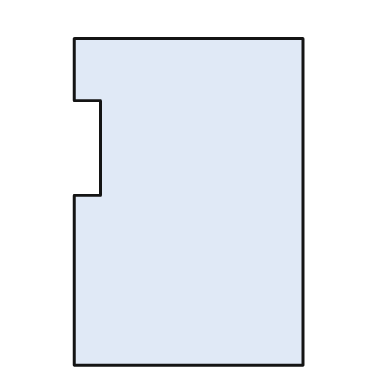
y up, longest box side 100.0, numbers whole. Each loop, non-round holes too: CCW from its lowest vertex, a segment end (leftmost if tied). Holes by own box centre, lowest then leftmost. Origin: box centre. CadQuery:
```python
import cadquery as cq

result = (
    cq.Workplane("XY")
    .moveTo(-35.0, -50.0)
    .lineTo(35.0, -50.0)
    .lineTo(35.0, 50.0)
    .lineTo(-35.0, 50.0)
    .lineTo(-35.0, 31.0)
    .lineTo(-27.0, 31.0)
    .lineTo(-27.0, 2.0)
    .lineTo(-35.0, 2.0)
    .close()
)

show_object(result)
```